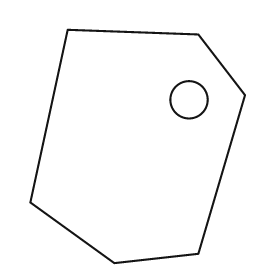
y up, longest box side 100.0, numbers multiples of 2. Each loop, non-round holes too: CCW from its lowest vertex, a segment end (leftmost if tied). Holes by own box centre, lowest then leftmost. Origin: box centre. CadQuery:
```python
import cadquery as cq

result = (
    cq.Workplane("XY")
    .moveTo(-10.0, -50.0)
    .lineTo(26.0, -46.0)
    .lineTo(46.0, 22.0)
    .lineTo(26.0, 48.0)
    .lineTo(-30.0, 50.0)
    .lineTo(-46.0, -24.0)
    .close()
    .moveTo(22.0, 20.0)
    .circle(8.0)
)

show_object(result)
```